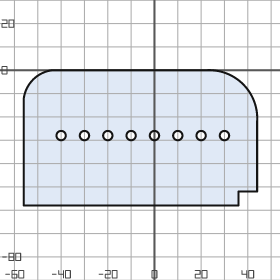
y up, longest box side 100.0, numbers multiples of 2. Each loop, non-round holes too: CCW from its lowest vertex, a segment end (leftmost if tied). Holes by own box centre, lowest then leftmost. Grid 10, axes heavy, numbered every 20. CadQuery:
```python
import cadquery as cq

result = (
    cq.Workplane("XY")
    .moveTo(-56.0, -58.0)
    .lineTo(36.0, -58.0)
    .lineTo(36.0, -52.0)
    .lineTo(44.0, -52.0)
    .lineTo(44.0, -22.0)
    .threePointArc((38.0, -6.0), (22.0, 0.0))
    .lineTo(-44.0, 0.0)
    .threePointArc((-52.0, -4.0), (-56.0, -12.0))
    .close()
    .moveTo(-40.0, -28.0)
    .circle(2.0)
    .moveTo(-30.0, -28.0)
    .circle(2.0)
    .moveTo(-20.0, -28.0)
    .circle(2.0)
    .moveTo(-10.0, -28.0)
    .circle(2.0)
    .moveTo(0.0, -28.0)
    .circle(2.0)
    .moveTo(10.0, -28.0)
    .circle(2.0)
    .moveTo(20.0, -28.0)
    .circle(2.0)
    .moveTo(30.0, -28.0)
    .circle(2.0)
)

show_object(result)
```